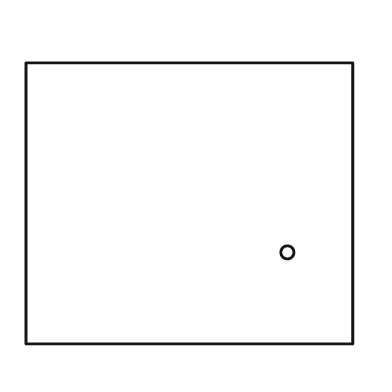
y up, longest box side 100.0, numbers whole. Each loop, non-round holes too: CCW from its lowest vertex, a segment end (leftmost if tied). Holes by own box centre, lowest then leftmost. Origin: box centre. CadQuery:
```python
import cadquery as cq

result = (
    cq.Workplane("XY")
    .moveTo(-50.0, -43.0)
    .lineTo(50.0, -43.0)
    .lineTo(50.0, 43.0)
    .lineTo(-50.0, 43.0)
    .close()
    .moveTo(30.0, -15.0)
    .circle(2.0)
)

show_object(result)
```